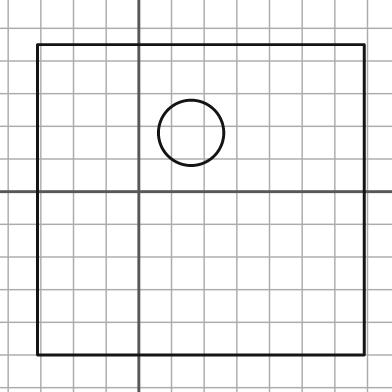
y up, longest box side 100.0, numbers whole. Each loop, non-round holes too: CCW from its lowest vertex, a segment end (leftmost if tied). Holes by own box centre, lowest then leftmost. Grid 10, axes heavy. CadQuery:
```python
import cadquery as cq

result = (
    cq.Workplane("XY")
    .moveTo(-31.0, -50.0)
    .lineTo(69.0, -50.0)
    .lineTo(69.0, 45.0)
    .lineTo(-31.0, 45.0)
    .close()
    .moveTo(16.0, 18.0)
    .circle(10.0)
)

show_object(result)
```